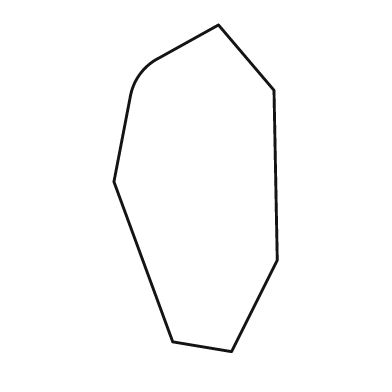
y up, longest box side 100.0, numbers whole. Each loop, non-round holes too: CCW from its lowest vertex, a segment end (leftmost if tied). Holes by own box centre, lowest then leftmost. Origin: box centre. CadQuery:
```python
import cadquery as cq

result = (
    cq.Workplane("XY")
    .moveTo(11.0, -50.0)
    .lineTo(25.0, -22.0)
    .lineTo(24.0, 30.0)
    .lineTo(7.0, 50.0)
    .lineTo(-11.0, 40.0)
    .threePointArc((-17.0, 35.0), (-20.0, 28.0))
    .lineTo(-25.0, 2.0)
    .lineTo(-7.0, -47.0)
    .close()
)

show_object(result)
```